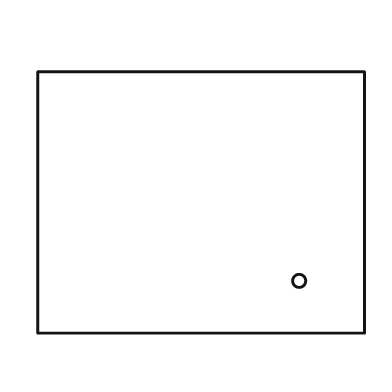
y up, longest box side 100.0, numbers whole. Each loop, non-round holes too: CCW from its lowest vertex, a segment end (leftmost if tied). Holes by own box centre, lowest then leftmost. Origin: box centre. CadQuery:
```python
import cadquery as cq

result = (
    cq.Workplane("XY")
    .moveTo(-50.0, -40.0)
    .lineTo(50.0, -40.0)
    .lineTo(50.0, 40.0)
    .lineTo(-50.0, 40.0)
    .close()
    .moveTo(30.0, -24.0)
    .circle(2.0)
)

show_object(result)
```